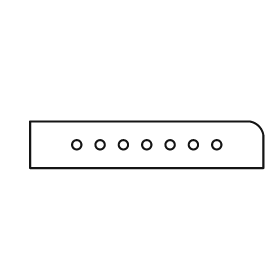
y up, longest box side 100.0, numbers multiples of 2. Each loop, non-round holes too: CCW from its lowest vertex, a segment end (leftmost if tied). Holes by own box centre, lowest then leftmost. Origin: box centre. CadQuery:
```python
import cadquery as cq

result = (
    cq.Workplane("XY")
    .moveTo(-50.0, -10.0)
    .lineTo(50.0, -10.0)
    .lineTo(50.0, 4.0)
    .threePointArc((48.0, 8.0), (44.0, 10.0))
    .lineTo(-50.0, 10.0)
    .close()
    .moveTo(-30.0, 0.0)
    .circle(2.0)
    .moveTo(-20.0, 0.0)
    .circle(2.0)
    .moveTo(-10.0, 0.0)
    .circle(2.0)
    .moveTo(0.0, 0.0)
    .circle(2.0)
    .moveTo(10.0, 0.0)
    .circle(2.0)
    .moveTo(20.0, 0.0)
    .circle(2.0)
    .moveTo(30.0, 0.0)
    .circle(2.0)
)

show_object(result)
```